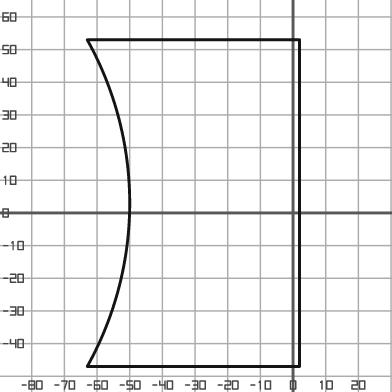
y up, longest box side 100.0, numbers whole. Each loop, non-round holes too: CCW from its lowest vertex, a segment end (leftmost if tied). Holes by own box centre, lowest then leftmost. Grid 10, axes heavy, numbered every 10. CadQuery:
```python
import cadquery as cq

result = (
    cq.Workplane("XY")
    .moveTo(-63.0, -47.0)
    .lineTo(2.0, -47.0)
    .lineTo(2.0, 53.0)
    .lineTo(-63.0, 53.0)
    .threePointArc((-50.0, 3.0), (-63.0, -47.0))
    .close()
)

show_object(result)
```